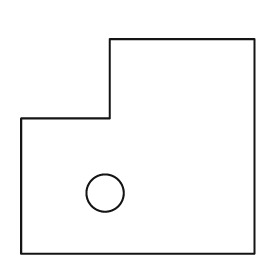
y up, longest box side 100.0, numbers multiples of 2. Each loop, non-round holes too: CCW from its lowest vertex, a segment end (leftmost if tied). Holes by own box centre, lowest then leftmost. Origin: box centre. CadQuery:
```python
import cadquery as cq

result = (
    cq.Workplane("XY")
    .moveTo(-50.0, -46.0)
    .lineTo(50.0, -46.0)
    .lineTo(50.0, 46.0)
    .lineTo(-12.0, 46.0)
    .lineTo(-12.0, 12.0)
    .lineTo(-50.0, 12.0)
    .close()
    .moveTo(-14.0, -20.0)
    .circle(8.0)
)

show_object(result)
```